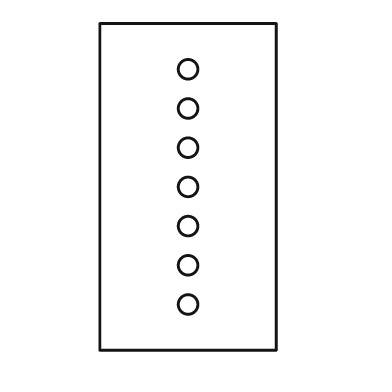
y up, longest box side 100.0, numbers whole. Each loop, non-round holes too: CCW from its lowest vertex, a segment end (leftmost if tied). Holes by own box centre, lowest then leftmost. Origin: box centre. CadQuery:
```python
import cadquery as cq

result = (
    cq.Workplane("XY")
    .moveTo(-27.0, -50.0)
    .lineTo(27.0, -50.0)
    .lineTo(27.0, 50.0)
    .lineTo(-27.0, 50.0)
    .close()
    .moveTo(0.0, -36.0)
    .circle(3.0)
    .moveTo(0.0, -24.0)
    .circle(3.0)
    .moveTo(0.0, -12.0)
    .circle(3.0)
    .moveTo(0.0, 0.0)
    .circle(3.0)
    .moveTo(0.0, 12.0)
    .circle(3.0)
    .moveTo(0.0, 24.0)
    .circle(3.0)
    .moveTo(0.0, 36.0)
    .circle(3.0)
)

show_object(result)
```